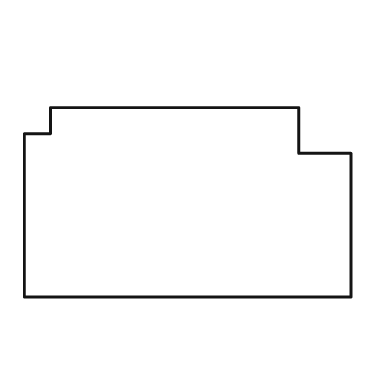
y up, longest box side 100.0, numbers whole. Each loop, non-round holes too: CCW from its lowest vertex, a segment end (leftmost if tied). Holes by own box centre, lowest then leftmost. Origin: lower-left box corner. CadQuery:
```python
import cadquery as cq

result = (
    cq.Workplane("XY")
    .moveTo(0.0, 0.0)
    .lineTo(100.0, 0.0)
    .lineTo(100.0, 44.0)
    .lineTo(84.0, 44.0)
    .lineTo(84.0, 58.0)
    .lineTo(8.0, 58.0)
    .lineTo(8.0, 50.0)
    .lineTo(0.0, 50.0)
    .close()
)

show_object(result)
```